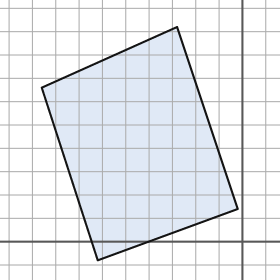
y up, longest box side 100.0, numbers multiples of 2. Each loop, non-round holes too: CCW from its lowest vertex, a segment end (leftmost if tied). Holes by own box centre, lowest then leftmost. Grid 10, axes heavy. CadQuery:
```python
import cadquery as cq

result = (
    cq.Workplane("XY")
    .moveTo(-62.0, -8.0)
    .lineTo(-2.0, 14.0)
    .lineTo(-28.0, 92.0)
    .lineTo(-86.0, 66.0)
    .close()
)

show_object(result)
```